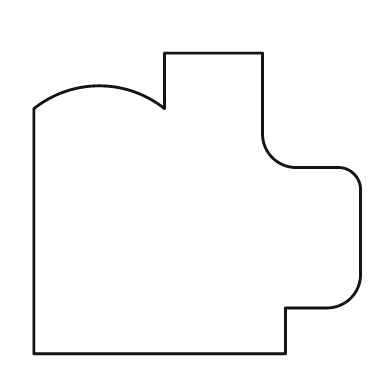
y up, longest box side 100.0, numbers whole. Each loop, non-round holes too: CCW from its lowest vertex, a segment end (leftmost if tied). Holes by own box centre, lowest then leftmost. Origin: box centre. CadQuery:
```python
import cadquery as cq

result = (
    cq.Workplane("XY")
    .moveTo(-50.0, -46.0)
    .lineTo(27.0, -46.0)
    .lineTo(27.0, -32.0)
    .lineTo(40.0, -32.0)
    .threePointArc((47.0, -29.0), (50.0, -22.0))
    .lineTo(50.0, 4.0)
    .threePointArc((48.0, 9.0), (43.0, 11.0))
    .lineTo(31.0, 11.0)
    .threePointArc((23.0, 14.0), (20.0, 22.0))
    .lineTo(20.0, 46.0)
    .lineTo(-10.0, 46.0)
    .lineTo(-10.0, 29.0)
    .threePointArc((-30.0, 36.0), (-50.0, 29.0))
    .close()
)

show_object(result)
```